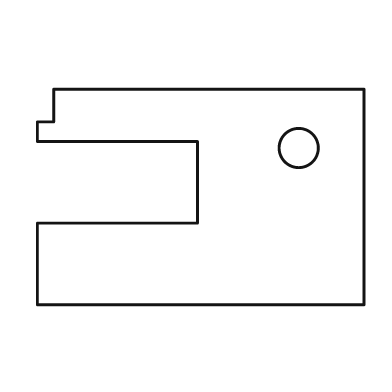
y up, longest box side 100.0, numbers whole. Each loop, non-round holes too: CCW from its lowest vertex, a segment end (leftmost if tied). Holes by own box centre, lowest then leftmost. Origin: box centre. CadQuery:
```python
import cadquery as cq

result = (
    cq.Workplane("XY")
    .moveTo(-50.0, -33.0)
    .lineTo(50.0, -33.0)
    .lineTo(50.0, 33.0)
    .lineTo(-45.0, 33.0)
    .lineTo(-45.0, 23.0)
    .lineTo(-50.0, 23.0)
    .lineTo(-50.0, 17.0)
    .lineTo(-1.0, 17.0)
    .lineTo(-1.0, -8.0)
    .lineTo(-50.0, -8.0)
    .close()
    .moveTo(30.0, 15.0)
    .circle(6.0)
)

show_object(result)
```